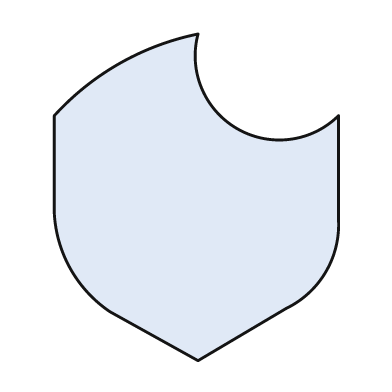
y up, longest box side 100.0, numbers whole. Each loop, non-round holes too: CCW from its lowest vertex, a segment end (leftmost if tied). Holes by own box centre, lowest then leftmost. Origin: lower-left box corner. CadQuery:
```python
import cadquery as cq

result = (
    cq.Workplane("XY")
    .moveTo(44.0, 0.0)
    .lineTo(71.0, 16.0)
    .threePointArc((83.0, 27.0), (87.0, 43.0))
    .lineTo(87.0, 75.0)
    .threePointArc((56.0, 71.0), (44.0, 100.0))
    .threePointArc((20.0, 91.0), (0.0, 75.0))
    .lineTo(0.0, 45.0)
    .threePointArc((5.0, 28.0), (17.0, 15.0))
    .close()
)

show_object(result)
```